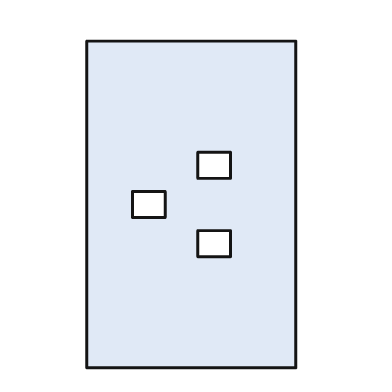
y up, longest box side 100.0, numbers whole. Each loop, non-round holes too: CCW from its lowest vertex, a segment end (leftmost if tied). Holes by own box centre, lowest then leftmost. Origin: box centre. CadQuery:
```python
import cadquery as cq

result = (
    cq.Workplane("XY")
    .moveTo(-32.0, -50.0)
    .lineTo(32.0, -50.0)
    .lineTo(32.0, 50.0)
    .lineTo(-32.0, 50.0)
    .close()
    .moveTo(2.0, -16.0)
    .lineTo(12.0, -16.0)
    .lineTo(12.0, -8.0)
    .lineTo(2.0, -8.0)
    .close()
    .moveTo(-18.0, -4.0)
    .lineTo(-8.0, -4.0)
    .lineTo(-8.0, 4.0)
    .lineTo(-18.0, 4.0)
    .close()
    .moveTo(2.0, 8.0)
    .lineTo(12.0, 8.0)
    .lineTo(12.0, 16.0)
    .lineTo(2.0, 16.0)
    .close()
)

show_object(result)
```